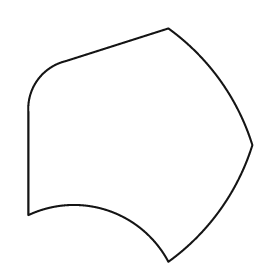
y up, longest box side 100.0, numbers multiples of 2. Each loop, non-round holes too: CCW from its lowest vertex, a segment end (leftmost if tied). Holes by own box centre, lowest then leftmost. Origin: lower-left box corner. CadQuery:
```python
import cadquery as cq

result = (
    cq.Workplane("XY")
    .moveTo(60.0, 0.0)
    .threePointArc((82.0, 22.0), (96.0, 50.0))
    .threePointArc((82.0, 78.0), (60.0, 100.0))
    .lineTo(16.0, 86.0)
    .threePointArc((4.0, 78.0), (0.0, 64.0))
    .lineTo(0.0, 20.0)
    .threePointArc((34.0, 22.0), (60.0, 0.0))
    .close()
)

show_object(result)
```